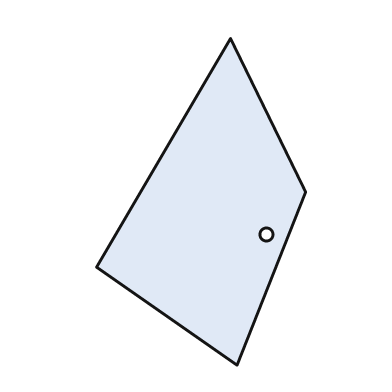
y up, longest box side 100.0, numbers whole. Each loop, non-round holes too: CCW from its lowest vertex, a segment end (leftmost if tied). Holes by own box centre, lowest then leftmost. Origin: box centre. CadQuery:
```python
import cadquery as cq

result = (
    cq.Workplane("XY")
    .moveTo(11.0, -50.0)
    .lineTo(32.0, 3.0)
    .lineTo(9.0, 50.0)
    .lineTo(-32.0, -20.0)
    .close()
    .moveTo(20.0, -10.0)
    .circle(2.0)
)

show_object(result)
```